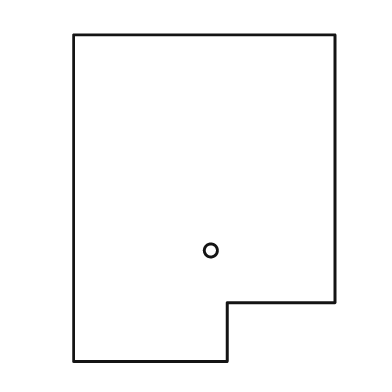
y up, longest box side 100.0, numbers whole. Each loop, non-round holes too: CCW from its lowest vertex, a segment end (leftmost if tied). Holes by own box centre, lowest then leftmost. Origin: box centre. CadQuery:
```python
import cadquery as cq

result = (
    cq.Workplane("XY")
    .moveTo(-40.0, -50.0)
    .lineTo(7.0, -50.0)
    .lineTo(7.0, -32.0)
    .lineTo(40.0, -32.0)
    .lineTo(40.0, 50.0)
    .lineTo(-40.0, 50.0)
    .close()
    .moveTo(2.0, -16.0)
    .circle(2.0)
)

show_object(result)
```